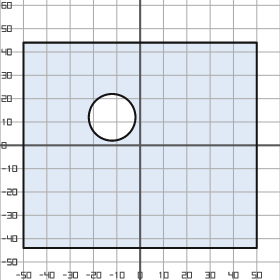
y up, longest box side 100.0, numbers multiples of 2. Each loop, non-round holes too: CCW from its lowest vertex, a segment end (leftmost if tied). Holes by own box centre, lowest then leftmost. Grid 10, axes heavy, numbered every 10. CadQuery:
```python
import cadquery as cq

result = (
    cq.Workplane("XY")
    .moveTo(-50.0, -44.0)
    .lineTo(50.0, -44.0)
    .lineTo(50.0, 44.0)
    .lineTo(-50.0, 44.0)
    .close()
    .moveTo(-12.0, 12.0)
    .circle(10.0)
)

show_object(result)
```